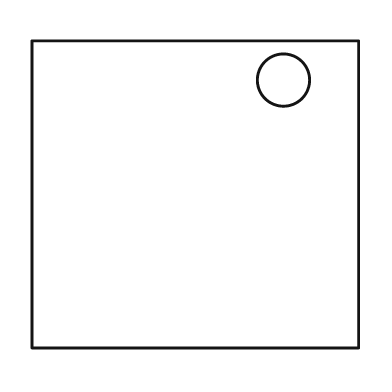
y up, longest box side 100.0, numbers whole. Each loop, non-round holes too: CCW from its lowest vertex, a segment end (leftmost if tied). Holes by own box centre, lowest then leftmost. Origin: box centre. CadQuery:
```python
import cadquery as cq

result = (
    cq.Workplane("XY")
    .moveTo(-50.0, -47.0)
    .lineTo(50.0, -47.0)
    .lineTo(50.0, 47.0)
    .lineTo(-50.0, 47.0)
    .close()
    .moveTo(27.0, 35.0)
    .circle(8.0)
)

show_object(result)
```